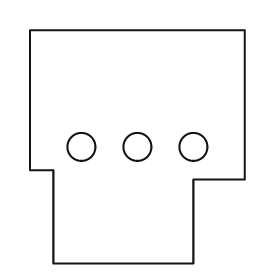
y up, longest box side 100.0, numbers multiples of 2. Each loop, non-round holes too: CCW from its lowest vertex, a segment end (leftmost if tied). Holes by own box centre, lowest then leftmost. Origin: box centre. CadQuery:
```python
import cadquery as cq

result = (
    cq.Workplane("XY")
    .moveTo(-36.0, -50.0)
    .lineTo(24.0, -50.0)
    .lineTo(24.0, -14.0)
    .lineTo(46.0, -14.0)
    .lineTo(46.0, 50.0)
    .lineTo(-46.0, 50.0)
    .lineTo(-46.0, -10.0)
    .lineTo(-36.0, -10.0)
    .close()
    .moveTo(-24.0, 0.0)
    .circle(6.0)
    .moveTo(0.0, 0.0)
    .circle(6.0)
    .moveTo(24.0, 0.0)
    .circle(6.0)
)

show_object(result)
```